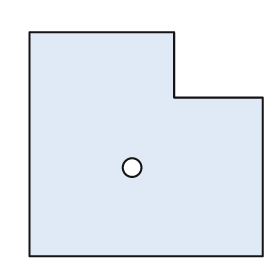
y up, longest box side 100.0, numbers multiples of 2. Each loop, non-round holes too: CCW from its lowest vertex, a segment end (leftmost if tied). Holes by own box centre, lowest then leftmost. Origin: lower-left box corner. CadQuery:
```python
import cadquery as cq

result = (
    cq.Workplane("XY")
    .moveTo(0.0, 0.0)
    .lineTo(100.0, 0.0)
    .lineTo(100.0, 68.0)
    .lineTo(62.0, 68.0)
    .lineTo(62.0, 96.0)
    .lineTo(0.0, 96.0)
    .close()
    .moveTo(44.0, 38.0)
    .circle(4.0)
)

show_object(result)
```